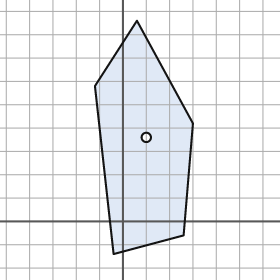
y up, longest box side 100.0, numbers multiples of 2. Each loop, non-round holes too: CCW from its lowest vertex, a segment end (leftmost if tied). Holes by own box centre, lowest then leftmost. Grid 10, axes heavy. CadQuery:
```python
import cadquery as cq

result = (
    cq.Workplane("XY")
    .moveTo(-4.0, -14.0)
    .lineTo(26.0, -6.0)
    .lineTo(30.0, 42.0)
    .lineTo(6.0, 86.0)
    .lineTo(-12.0, 58.0)
    .close()
    .moveTo(10.0, 36.0)
    .circle(2.0)
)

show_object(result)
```